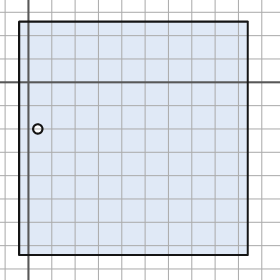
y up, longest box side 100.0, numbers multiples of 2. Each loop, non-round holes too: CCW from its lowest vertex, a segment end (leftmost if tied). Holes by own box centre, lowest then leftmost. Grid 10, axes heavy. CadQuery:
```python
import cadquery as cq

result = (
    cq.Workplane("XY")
    .moveTo(-4.0, -74.0)
    .lineTo(94.0, -74.0)
    .lineTo(94.0, 26.0)
    .lineTo(-4.0, 26.0)
    .close()
    .moveTo(4.0, -20.0)
    .circle(2.0)
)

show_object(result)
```